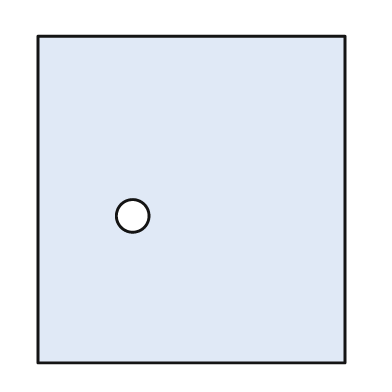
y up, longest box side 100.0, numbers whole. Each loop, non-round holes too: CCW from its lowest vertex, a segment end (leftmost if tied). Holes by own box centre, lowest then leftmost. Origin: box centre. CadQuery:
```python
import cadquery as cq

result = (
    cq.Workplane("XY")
    .moveTo(-47.0, -50.0)
    .lineTo(47.0, -50.0)
    .lineTo(47.0, 50.0)
    .lineTo(-47.0, 50.0)
    .close()
    .moveTo(-18.0, -5.0)
    .circle(5.0)
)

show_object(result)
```